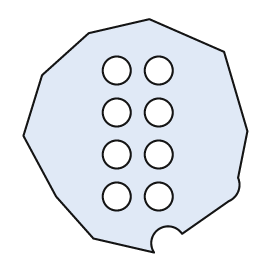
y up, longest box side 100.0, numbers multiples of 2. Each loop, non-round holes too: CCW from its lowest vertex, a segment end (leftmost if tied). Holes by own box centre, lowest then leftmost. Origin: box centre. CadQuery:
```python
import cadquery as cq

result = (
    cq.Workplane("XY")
    .moveTo(8.0, -50.0)
    .threePointArc((10.0, -40.0), (20.0, -42.0))
    .lineTo(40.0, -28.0)
    .threePointArc((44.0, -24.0), (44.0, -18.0))
    .lineTo(48.0, 2.0)
    .lineTo(38.0, 36.0)
    .lineTo(6.0, 50.0)
    .lineTo(-20.0, 44.0)
    .lineTo(-40.0, 26.0)
    .lineTo(-48.0, 0.0)
    .lineTo(-34.0, -26.0)
    .lineTo(-18.0, -44.0)
    .close()
    .moveTo(-8.0, -26.0)
    .circle(6.0)
    .moveTo(10.0, -26.0)
    .circle(6.0)
    .moveTo(-8.0, -8.0)
    .circle(6.0)
    .moveTo(10.0, -8.0)
    .circle(6.0)
    .moveTo(-8.0, 10.0)
    .circle(6.0)
    .moveTo(10.0, 10.0)
    .circle(6.0)
    .moveTo(-8.0, 28.0)
    .circle(6.0)
    .moveTo(10.0, 28.0)
    .circle(6.0)
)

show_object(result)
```